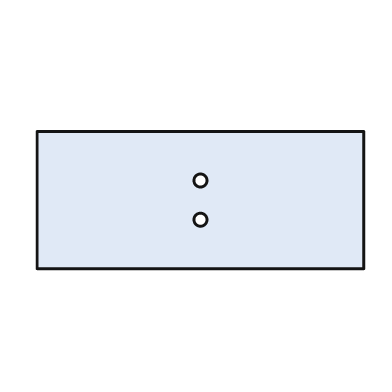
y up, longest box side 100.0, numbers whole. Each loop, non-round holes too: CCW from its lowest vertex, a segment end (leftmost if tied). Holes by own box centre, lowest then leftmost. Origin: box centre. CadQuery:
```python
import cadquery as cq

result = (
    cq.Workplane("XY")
    .moveTo(-50.0, -21.0)
    .lineTo(50.0, -21.0)
    .lineTo(50.0, 21.0)
    .lineTo(-50.0, 21.0)
    .close()
    .moveTo(0.0, -6.0)
    .circle(2.0)
    .moveTo(0.0, 6.0)
    .circle(2.0)
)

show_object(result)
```